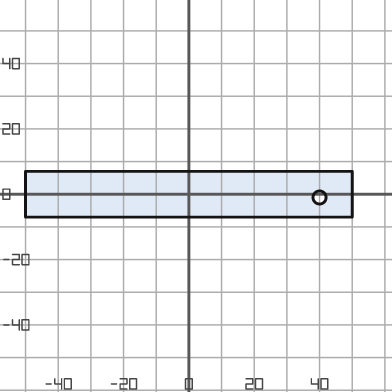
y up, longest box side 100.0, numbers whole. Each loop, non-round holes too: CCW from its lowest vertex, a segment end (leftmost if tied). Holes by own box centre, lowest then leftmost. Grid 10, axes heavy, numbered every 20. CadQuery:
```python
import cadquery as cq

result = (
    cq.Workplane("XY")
    .moveTo(-50.0, -7.0)
    .lineTo(50.0, -7.0)
    .lineTo(50.0, 7.0)
    .lineTo(-50.0, 7.0)
    .close()
    .moveTo(40.0, -1.0)
    .circle(2.0)
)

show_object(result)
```